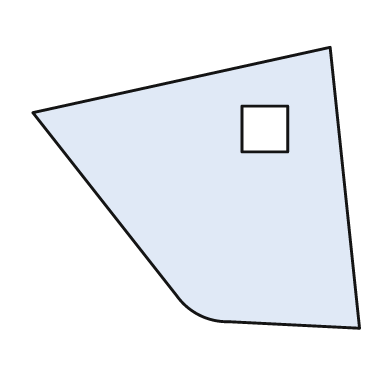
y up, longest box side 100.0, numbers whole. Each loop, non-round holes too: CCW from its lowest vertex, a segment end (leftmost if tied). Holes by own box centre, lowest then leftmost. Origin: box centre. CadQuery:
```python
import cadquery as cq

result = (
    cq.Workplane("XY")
    .moveTo(50.0, -43.0)
    .lineTo(41.0, 43.0)
    .lineTo(-50.0, 23.0)
    .lineTo(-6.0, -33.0)
    .threePointArc((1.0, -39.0), (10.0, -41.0))
    .close()
    .moveTo(14.0, 11.0)
    .lineTo(28.0, 11.0)
    .lineTo(28.0, 25.0)
    .lineTo(14.0, 25.0)
    .close()
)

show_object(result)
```